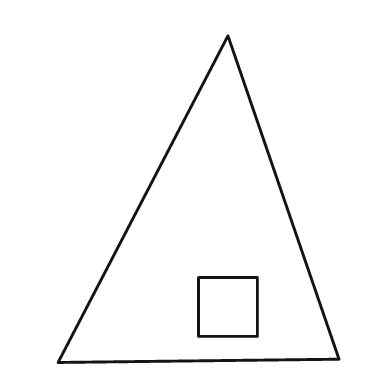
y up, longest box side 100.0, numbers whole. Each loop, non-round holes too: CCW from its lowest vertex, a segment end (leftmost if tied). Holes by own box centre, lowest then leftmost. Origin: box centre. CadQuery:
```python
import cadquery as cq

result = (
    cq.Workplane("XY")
    .moveTo(-43.0, -50.0)
    .lineTo(43.0, -49.0)
    .lineTo(9.0, 50.0)
    .close()
    .moveTo(0.0, -42.0)
    .lineTo(18.0, -42.0)
    .lineTo(18.0, -24.0)
    .lineTo(0.0, -24.0)
    .close()
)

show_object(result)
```